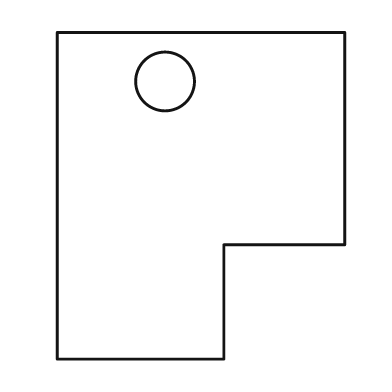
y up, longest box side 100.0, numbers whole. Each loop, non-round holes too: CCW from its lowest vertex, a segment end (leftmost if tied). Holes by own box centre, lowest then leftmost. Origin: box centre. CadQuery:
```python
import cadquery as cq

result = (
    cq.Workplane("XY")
    .moveTo(-44.0, -50.0)
    .lineTo(7.0, -50.0)
    .lineTo(7.0, -15.0)
    .lineTo(44.0, -15.0)
    .lineTo(44.0, 50.0)
    .lineTo(-44.0, 50.0)
    .close()
    .moveTo(-11.0, 35.0)
    .circle(9.0)
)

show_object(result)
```